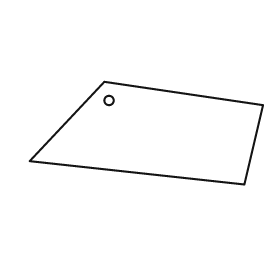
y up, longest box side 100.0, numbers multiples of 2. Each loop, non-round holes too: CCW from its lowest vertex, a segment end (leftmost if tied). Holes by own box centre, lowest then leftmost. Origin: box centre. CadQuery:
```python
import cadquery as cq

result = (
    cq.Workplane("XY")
    .moveTo(42.0, -22.0)
    .lineTo(50.0, 12.0)
    .lineTo(-18.0, 22.0)
    .lineTo(-50.0, -12.0)
    .close()
    .moveTo(-16.0, 14.0)
    .circle(2.0)
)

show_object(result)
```